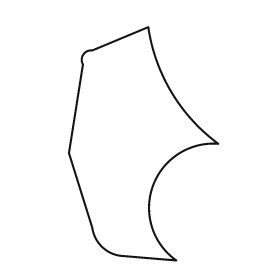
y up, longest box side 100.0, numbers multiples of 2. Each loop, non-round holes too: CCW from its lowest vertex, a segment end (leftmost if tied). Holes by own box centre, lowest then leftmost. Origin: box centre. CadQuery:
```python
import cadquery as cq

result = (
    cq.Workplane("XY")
    .moveTo(14.0, -50.0)
    .threePointArc((4.0, -18.0), (32.0, 0.0))
    .threePointArc((12.0, 22.0), (2.0, 50.0))
    .lineTo(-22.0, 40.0)
    .threePointArc((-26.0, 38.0), (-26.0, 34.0))
    .lineTo(-32.0, -4.0)
    .lineTo(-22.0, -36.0)
    .threePointArc((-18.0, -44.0), (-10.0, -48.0))
    .close()
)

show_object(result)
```